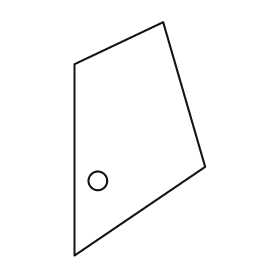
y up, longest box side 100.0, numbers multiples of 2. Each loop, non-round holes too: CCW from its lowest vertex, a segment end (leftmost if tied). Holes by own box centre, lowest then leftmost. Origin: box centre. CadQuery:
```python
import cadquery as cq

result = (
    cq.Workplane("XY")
    .moveTo(-28.0, -50.0)
    .lineTo(28.0, -12.0)
    .lineTo(10.0, 50.0)
    .lineTo(-28.0, 32.0)
    .close()
    .moveTo(-18.0, -18.0)
    .circle(4.0)
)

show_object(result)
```